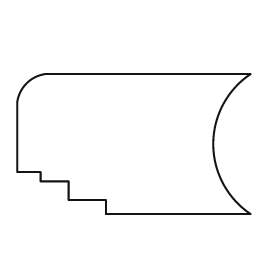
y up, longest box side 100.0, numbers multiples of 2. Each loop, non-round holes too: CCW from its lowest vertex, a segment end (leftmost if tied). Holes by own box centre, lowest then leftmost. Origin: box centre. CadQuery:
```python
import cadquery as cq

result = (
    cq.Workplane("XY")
    .moveTo(-12.0, -30.0)
    .lineTo(50.0, -30.0)
    .threePointArc((34.0, 0.0), (50.0, 30.0))
    .lineTo(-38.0, 30.0)
    .threePointArc((-46.0, 26.0), (-50.0, 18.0))
    .lineTo(-50.0, -12.0)
    .lineTo(-40.0, -12.0)
    .lineTo(-40.0, -16.0)
    .lineTo(-28.0, -16.0)
    .lineTo(-28.0, -24.0)
    .lineTo(-12.0, -24.0)
    .close()
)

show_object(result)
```